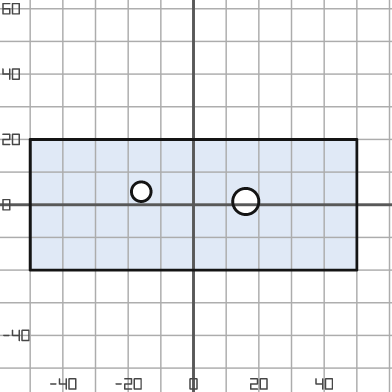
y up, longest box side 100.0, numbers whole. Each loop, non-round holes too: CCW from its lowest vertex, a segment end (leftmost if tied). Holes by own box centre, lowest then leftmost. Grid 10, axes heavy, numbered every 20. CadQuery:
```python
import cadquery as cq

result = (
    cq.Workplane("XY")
    .moveTo(-50.0, -20.0)
    .lineTo(50.0, -20.0)
    .lineTo(50.0, 20.0)
    .lineTo(-50.0, 20.0)
    .close()
    .moveTo(16.0, 1.0)
    .circle(4.0)
    .moveTo(-16.0, 4.0)
    .circle(3.0)
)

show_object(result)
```